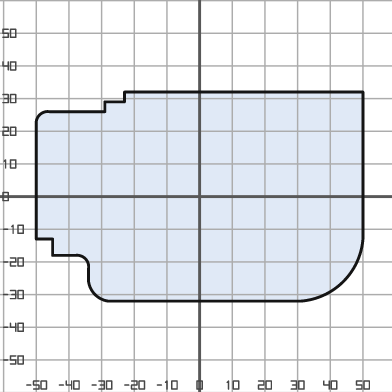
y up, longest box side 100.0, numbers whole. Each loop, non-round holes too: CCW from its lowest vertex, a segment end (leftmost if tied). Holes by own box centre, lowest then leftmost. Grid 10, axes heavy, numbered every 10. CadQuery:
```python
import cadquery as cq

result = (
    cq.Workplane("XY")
    .moveTo(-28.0, -32.0)
    .lineTo(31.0, -32.0)
    .threePointArc((44.0, -26.0), (50.0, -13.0))
    .lineTo(50.0, 32.0)
    .lineTo(-23.0, 32.0)
    .lineTo(-23.0, 29.0)
    .lineTo(-29.0, 29.0)
    .lineTo(-29.0, 26.0)
    .lineTo(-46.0, 26.0)
    .threePointArc((-49.0, 25.0), (-50.0, 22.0))
    .lineTo(-50.0, -13.0)
    .lineTo(-45.0, -13.0)
    .lineTo(-45.0, -18.0)
    .lineTo(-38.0, -18.0)
    .threePointArc((-35.0, -19.0), (-34.0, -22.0))
    .lineTo(-34.0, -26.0)
    .threePointArc((-32.0, -30.0), (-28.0, -32.0))
    .close()
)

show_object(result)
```